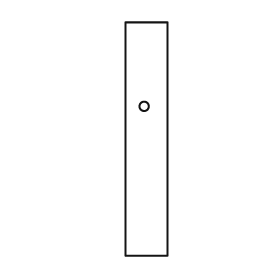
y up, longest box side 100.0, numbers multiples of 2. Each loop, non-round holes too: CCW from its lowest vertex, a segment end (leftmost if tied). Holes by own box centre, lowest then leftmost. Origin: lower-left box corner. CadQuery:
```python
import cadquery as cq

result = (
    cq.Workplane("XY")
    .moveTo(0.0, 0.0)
    .lineTo(18.0, 0.0)
    .lineTo(18.0, 100.0)
    .lineTo(0.0, 100.0)
    .close()
    .moveTo(8.0, 64.0)
    .circle(2.0)
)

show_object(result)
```